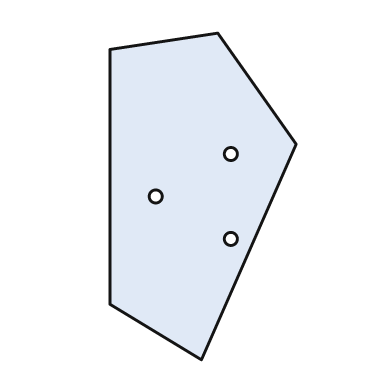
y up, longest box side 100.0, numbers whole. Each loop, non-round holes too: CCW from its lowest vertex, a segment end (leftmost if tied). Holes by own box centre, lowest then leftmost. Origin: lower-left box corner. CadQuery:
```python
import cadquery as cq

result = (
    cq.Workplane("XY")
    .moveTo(28.0, 0.0)
    .lineTo(57.0, 66.0)
    .lineTo(33.0, 100.0)
    .lineTo(0.0, 95.0)
    .lineTo(0.0, 17.0)
    .close()
    .moveTo(37.0, 37.0)
    .circle(2.0)
    .moveTo(14.0, 50.0)
    .circle(2.0)
    .moveTo(37.0, 63.0)
    .circle(2.0)
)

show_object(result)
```